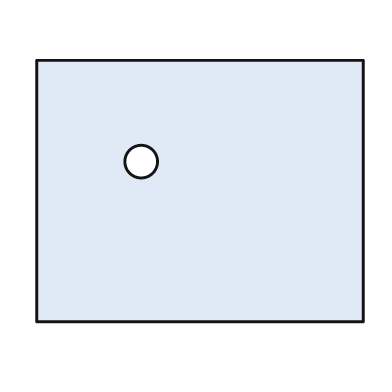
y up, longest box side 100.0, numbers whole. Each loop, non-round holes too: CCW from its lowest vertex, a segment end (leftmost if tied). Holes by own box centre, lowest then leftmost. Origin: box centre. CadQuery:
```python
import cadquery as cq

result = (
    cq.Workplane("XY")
    .moveTo(-50.0, -40.0)
    .lineTo(50.0, -40.0)
    .lineTo(50.0, 40.0)
    .lineTo(-50.0, 40.0)
    .close()
    .moveTo(-18.0, 9.0)
    .circle(5.0)
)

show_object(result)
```